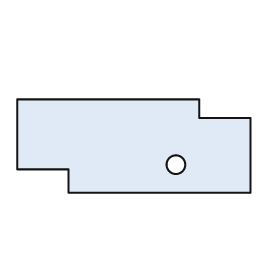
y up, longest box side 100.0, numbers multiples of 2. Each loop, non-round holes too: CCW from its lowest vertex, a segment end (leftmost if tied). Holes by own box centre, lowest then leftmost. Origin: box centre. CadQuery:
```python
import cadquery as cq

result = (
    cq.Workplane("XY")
    .moveTo(-28.0, -20.0)
    .lineTo(50.0, -20.0)
    .lineTo(50.0, 12.0)
    .lineTo(28.0, 12.0)
    .lineTo(28.0, 20.0)
    .lineTo(-50.0, 20.0)
    .lineTo(-50.0, -10.0)
    .lineTo(-28.0, -10.0)
    .close()
    .moveTo(18.0, -8.0)
    .circle(4.0)
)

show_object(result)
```